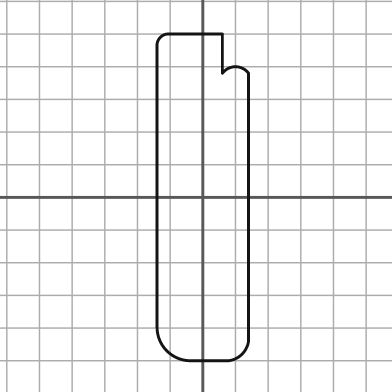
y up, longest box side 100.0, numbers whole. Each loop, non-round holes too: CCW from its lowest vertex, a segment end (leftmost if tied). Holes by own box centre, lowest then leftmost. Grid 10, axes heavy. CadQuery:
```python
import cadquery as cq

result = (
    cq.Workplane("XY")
    .moveTo(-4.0, -50.0)
    .lineTo(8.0, -50.0)
    .threePointArc((12.0, -48.0), (14.0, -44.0))
    .lineTo(14.0, 38.0)
    .threePointArc((10.0, 40.0), (6.0, 38.0))
    .lineTo(6.0, 50.0)
    .lineTo(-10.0, 50.0)
    .threePointArc((-13.0, 49.0), (-14.0, 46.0))
    .lineTo(-14.0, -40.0)
    .threePointArc((-11.0, -47.0), (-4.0, -50.0))
    .close()
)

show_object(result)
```